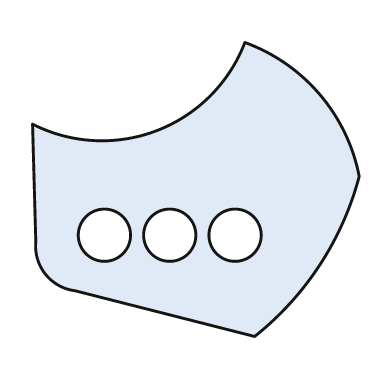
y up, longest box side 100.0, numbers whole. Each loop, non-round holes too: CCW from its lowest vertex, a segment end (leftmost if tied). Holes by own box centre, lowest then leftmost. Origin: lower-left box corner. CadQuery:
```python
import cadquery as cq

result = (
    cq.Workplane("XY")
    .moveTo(68.0, 0.0)
    .threePointArc((88.0, 22.0), (100.0, 49.0))
    .threePointArc((88.0, 74.0), (65.0, 90.0))
    .threePointArc((38.0, 63.0), (0.0, 65.0))
    .lineTo(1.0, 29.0)
    .threePointArc((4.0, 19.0), (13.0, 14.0))
    .close()
    .moveTo(22.0, 31.0)
    .circle(8.0)
    .moveTo(42.0, 31.0)
    .circle(8.0)
    .moveTo(62.0, 31.0)
    .circle(8.0)
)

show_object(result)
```